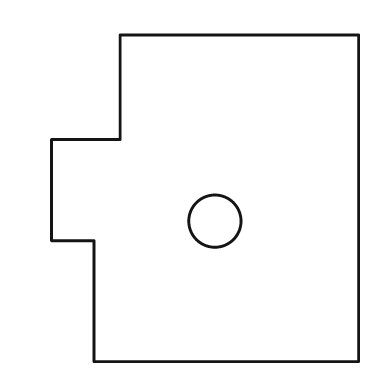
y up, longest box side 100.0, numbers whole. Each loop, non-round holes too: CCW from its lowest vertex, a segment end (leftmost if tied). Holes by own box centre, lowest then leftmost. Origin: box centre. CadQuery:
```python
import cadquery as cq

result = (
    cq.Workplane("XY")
    .moveTo(-34.0, -50.0)
    .lineTo(47.0, -50.0)
    .lineTo(47.0, 50.0)
    .lineTo(-26.0, 50.0)
    .lineTo(-26.0, 18.0)
    .lineTo(-47.0, 18.0)
    .lineTo(-47.0, -13.0)
    .lineTo(-34.0, -13.0)
    .close()
    .moveTo(3.0, -7.0)
    .circle(8.0)
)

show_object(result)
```